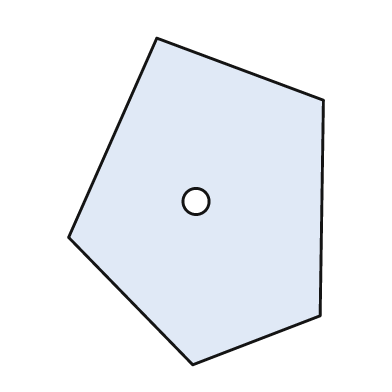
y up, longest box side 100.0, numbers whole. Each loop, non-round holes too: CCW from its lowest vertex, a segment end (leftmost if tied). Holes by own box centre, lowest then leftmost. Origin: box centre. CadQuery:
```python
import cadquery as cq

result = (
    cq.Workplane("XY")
    .moveTo(-1.0, -50.0)
    .lineTo(38.0, -35.0)
    .lineTo(39.0, 31.0)
    .lineTo(-12.0, 50.0)
    .lineTo(-39.0, -11.0)
    .close()
    .moveTo(0.0, 0.0)
    .circle(4.0)
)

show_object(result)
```